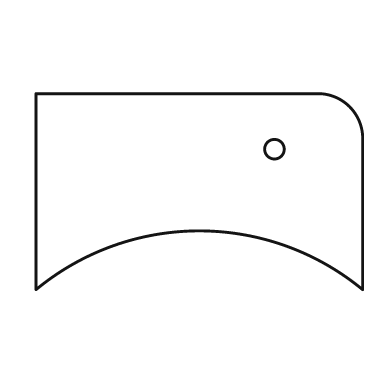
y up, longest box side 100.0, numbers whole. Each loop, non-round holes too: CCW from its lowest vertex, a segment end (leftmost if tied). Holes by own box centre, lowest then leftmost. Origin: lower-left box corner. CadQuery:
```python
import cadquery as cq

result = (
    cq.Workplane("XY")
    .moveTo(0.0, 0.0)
    .threePointArc((50.0, 18.0), (100.0, 0.0))
    .lineTo(100.0, 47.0)
    .threePointArc((96.0, 56.0), (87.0, 60.0))
    .lineTo(0.0, 60.0)
    .close()
    .moveTo(73.0, 43.0)
    .circle(3.0)
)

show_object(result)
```